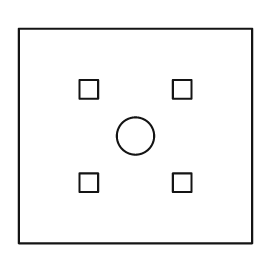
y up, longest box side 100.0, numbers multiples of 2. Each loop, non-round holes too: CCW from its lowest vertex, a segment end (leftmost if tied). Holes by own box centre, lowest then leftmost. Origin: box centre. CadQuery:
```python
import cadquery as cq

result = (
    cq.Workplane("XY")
    .moveTo(-50.0, -46.0)
    .lineTo(50.0, -46.0)
    .lineTo(50.0, 46.0)
    .lineTo(-50.0, 46.0)
    .close()
    .moveTo(-24.0, -24.0)
    .lineTo(-16.0, -24.0)
    .lineTo(-16.0, -16.0)
    .lineTo(-24.0, -16.0)
    .close()
    .moveTo(16.0, -24.0)
    .lineTo(24.0, -24.0)
    .lineTo(24.0, -16.0)
    .lineTo(16.0, -16.0)
    .close()
    .moveTo(0.0, 0.0)
    .circle(8.0)
    .moveTo(-24.0, 16.0)
    .lineTo(-16.0, 16.0)
    .lineTo(-16.0, 24.0)
    .lineTo(-24.0, 24.0)
    .close()
    .moveTo(16.0, 16.0)
    .lineTo(24.0, 16.0)
    .lineTo(24.0, 24.0)
    .lineTo(16.0, 24.0)
    .close()
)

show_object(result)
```